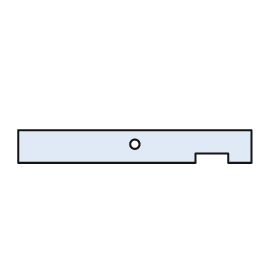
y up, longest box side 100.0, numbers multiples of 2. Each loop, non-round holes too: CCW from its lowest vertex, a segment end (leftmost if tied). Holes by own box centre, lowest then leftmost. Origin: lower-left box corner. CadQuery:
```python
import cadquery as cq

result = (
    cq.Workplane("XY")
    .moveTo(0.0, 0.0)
    .lineTo(76.0, 0.0)
    .lineTo(76.0, 4.0)
    .lineTo(90.0, 4.0)
    .lineTo(90.0, 0.0)
    .lineTo(100.0, 0.0)
    .lineTo(100.0, 14.0)
    .lineTo(0.0, 14.0)
    .close()
    .moveTo(50.0, 8.0)
    .circle(2.0)
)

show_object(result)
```